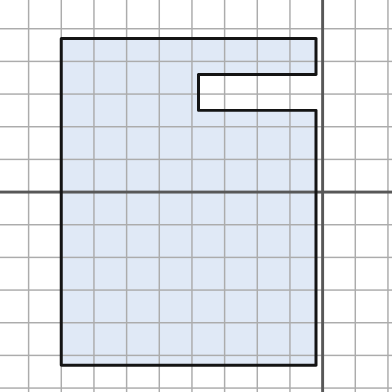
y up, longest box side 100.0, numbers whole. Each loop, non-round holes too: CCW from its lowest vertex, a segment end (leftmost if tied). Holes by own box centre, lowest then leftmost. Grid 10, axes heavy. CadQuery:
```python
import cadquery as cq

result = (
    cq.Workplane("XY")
    .moveTo(-80.0, -53.0)
    .lineTo(-2.0, -53.0)
    .lineTo(-2.0, 25.0)
    .lineTo(-38.0, 25.0)
    .lineTo(-38.0, 36.0)
    .lineTo(-2.0, 36.0)
    .lineTo(-2.0, 47.0)
    .lineTo(-80.0, 47.0)
    .close()
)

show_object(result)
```